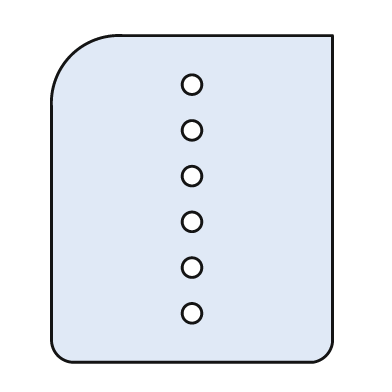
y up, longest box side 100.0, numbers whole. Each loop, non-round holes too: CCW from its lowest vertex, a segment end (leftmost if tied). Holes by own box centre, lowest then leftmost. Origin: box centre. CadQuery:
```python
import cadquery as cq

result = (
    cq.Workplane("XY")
    .moveTo(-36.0, -50.0)
    .lineTo(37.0, -50.0)
    .threePointArc((41.0, -48.0), (43.0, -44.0))
    .lineTo(43.0, 50.0)
    .lineTo(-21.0, 50.0)
    .threePointArc((-37.0, 44.0), (-43.0, 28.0))
    .lineTo(-43.0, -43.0)
    .threePointArc((-41.0, -48.0), (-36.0, -50.0))
    .close()
    .moveTo(0.0, -35.0)
    .circle(3.0)
    .moveTo(0.0, -21.0)
    .circle(3.0)
    .moveTo(0.0, -7.0)
    .circle(3.0)
    .moveTo(0.0, 7.0)
    .circle(3.0)
    .moveTo(0.0, 21.0)
    .circle(3.0)
    .moveTo(0.0, 35.0)
    .circle(3.0)
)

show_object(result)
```